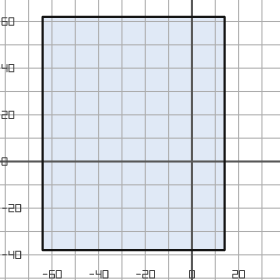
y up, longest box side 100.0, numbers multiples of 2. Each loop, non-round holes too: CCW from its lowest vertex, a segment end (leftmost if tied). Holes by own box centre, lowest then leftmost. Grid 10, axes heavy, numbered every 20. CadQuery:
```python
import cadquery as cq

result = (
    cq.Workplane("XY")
    .moveTo(-64.0, -38.0)
    .lineTo(14.0, -38.0)
    .lineTo(14.0, 62.0)
    .lineTo(-64.0, 62.0)
    .close()
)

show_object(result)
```